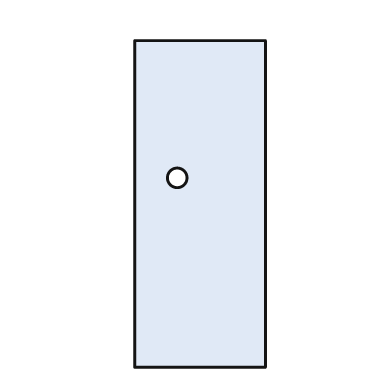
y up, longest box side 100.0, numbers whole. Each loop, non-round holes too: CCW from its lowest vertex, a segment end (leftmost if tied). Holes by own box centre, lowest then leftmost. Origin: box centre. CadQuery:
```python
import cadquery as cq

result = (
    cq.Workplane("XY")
    .moveTo(-20.0, -50.0)
    .lineTo(20.0, -50.0)
    .lineTo(20.0, 50.0)
    .lineTo(-20.0, 50.0)
    .close()
    .moveTo(-7.0, 8.0)
    .circle(3.0)
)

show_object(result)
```